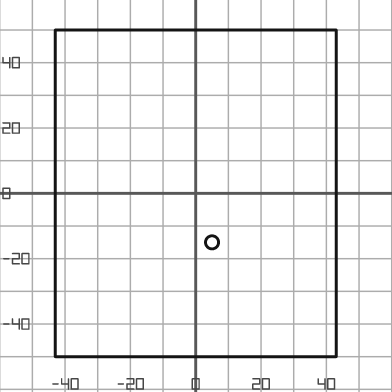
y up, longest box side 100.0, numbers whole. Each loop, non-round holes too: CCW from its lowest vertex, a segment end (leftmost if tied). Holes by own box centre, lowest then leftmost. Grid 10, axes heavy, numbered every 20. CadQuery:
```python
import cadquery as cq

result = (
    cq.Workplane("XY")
    .moveTo(-43.0, -50.0)
    .lineTo(43.0, -50.0)
    .lineTo(43.0, 50.0)
    .lineTo(-43.0, 50.0)
    .close()
    .moveTo(5.0, -15.0)
    .circle(2.0)
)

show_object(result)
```